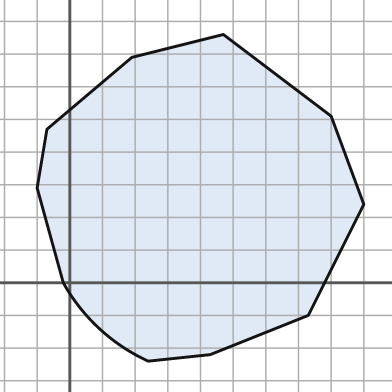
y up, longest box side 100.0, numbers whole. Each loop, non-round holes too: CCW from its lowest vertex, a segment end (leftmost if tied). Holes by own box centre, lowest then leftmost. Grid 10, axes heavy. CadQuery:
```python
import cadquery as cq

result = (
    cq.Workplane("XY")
    .moveTo(24.0, -24.0)
    .lineTo(43.0, -22.0)
    .lineTo(73.0, -10.0)
    .lineTo(90.0, 24.0)
    .lineTo(80.0, 51.0)
    .lineTo(47.0, 76.0)
    .lineTo(19.0, 69.0)
    .lineTo(-7.0, 47.0)
    .lineTo(-10.0, 29.0)
    .lineTo(-2.0, 0.0)
    .threePointArc((9.0, -14.0), (24.0, -24.0))
    .close()
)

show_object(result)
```